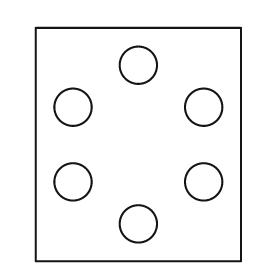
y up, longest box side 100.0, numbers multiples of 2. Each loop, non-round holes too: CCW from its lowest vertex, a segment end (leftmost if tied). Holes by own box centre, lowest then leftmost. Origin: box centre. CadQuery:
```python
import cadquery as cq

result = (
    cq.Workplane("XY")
    .moveTo(-44.0, -50.0)
    .lineTo(44.0, -50.0)
    .lineTo(44.0, 50.0)
    .lineTo(-44.0, 50.0)
    .close()
    .moveTo(0.0, -34.0)
    .circle(8.0)
    .moveTo(-28.0, -16.0)
    .circle(8.0)
    .moveTo(28.0, -16.0)
    .circle(8.0)
    .moveTo(-28.0, 16.0)
    .circle(8.0)
    .moveTo(28.0, 16.0)
    .circle(8.0)
    .moveTo(0.0, 34.0)
    .circle(8.0)
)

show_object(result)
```